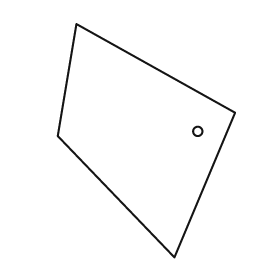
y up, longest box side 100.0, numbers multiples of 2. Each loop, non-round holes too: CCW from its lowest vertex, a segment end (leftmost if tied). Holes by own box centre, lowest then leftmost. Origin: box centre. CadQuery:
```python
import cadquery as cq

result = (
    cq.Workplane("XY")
    .moveTo(12.0, -50.0)
    .lineTo(38.0, 12.0)
    .lineTo(-30.0, 50.0)
    .lineTo(-38.0, 2.0)
    .close()
    .moveTo(22.0, 4.0)
    .circle(2.0)
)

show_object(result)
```